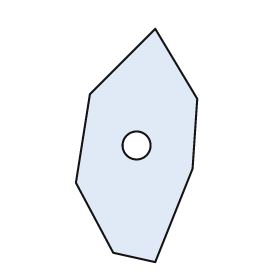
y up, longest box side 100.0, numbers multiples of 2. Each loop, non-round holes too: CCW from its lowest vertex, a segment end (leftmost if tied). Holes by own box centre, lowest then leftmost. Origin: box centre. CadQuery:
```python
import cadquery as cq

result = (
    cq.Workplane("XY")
    .moveTo(8.0, -50.0)
    .lineTo(24.0, -10.0)
    .lineTo(26.0, 20.0)
    .lineTo(8.0, 50.0)
    .lineTo(-20.0, 22.0)
    .lineTo(-26.0, -16.0)
    .lineTo(-10.0, -46.0)
    .close()
    .moveTo(0.0, 0.0)
    .circle(6.0)
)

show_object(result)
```